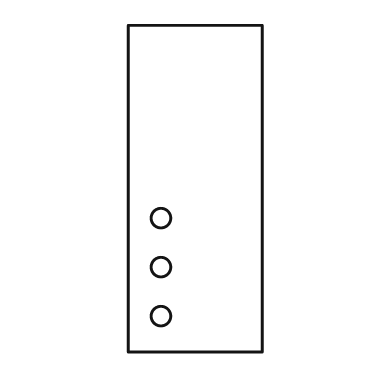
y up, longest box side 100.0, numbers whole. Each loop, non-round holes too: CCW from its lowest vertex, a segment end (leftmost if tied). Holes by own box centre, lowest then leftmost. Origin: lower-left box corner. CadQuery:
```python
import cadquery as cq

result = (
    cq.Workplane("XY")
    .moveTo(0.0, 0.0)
    .lineTo(41.0, 0.0)
    .lineTo(41.0, 100.0)
    .lineTo(0.0, 100.0)
    .close()
    .moveTo(10.0, 11.0)
    .circle(3.0)
    .moveTo(10.0, 26.0)
    .circle(3.0)
    .moveTo(10.0, 41.0)
    .circle(3.0)
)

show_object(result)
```